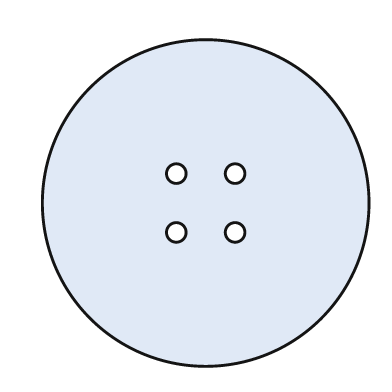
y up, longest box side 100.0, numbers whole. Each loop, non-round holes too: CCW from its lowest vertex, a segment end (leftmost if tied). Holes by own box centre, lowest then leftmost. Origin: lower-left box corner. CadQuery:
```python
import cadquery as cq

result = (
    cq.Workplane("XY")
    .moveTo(50.0, 50.0)
    .circle(50.0)
    .moveTo(41.0, 41.0)
    .circle(3.0)
    .moveTo(59.0, 41.0)
    .circle(3.0)
    .moveTo(41.0, 59.0)
    .circle(3.0)
    .moveTo(59.0, 59.0)
    .circle(3.0)
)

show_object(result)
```